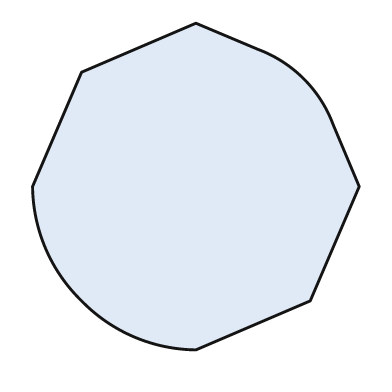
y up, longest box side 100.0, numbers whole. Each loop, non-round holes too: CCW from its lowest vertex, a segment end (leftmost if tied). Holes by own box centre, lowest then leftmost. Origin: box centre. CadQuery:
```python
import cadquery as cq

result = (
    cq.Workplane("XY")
    .moveTo(0.0, -50.0)
    .lineTo(35.0, -35.0)
    .lineTo(50.0, 0.0)
    .lineTo(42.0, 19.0)
    .threePointArc((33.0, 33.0), (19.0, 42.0))
    .lineTo(0.0, 50.0)
    .lineTo(-35.0, 35.0)
    .lineTo(-50.0, 0.0)
    .threePointArc((-46.0, -19.0), (-35.0, -35.0))
    .threePointArc((-19.0, -46.0), (0.0, -50.0))
    .close()
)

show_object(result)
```